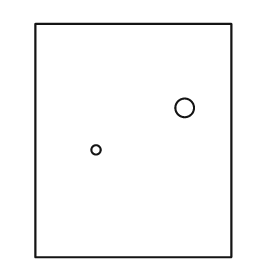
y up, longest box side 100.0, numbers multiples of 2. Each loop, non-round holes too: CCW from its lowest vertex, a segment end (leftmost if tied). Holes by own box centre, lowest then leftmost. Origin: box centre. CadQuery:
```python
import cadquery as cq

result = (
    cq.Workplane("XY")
    .moveTo(-42.0, -50.0)
    .lineTo(42.0, -50.0)
    .lineTo(42.0, 50.0)
    .lineTo(-42.0, 50.0)
    .close()
    .moveTo(-16.0, -4.0)
    .circle(2.0)
    .moveTo(22.0, 14.0)
    .circle(4.0)
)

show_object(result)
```